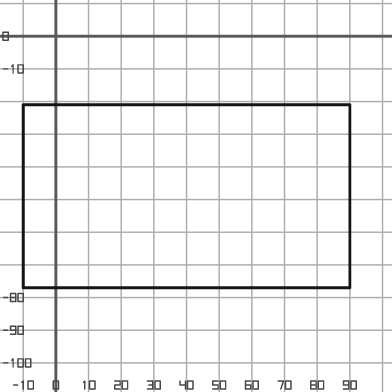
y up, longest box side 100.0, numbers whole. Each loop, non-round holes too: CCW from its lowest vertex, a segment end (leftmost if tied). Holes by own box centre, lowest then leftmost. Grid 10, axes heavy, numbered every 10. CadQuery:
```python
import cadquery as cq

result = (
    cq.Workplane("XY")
    .moveTo(-10.0, -77.0)
    .lineTo(90.0, -77.0)
    .lineTo(90.0, -21.0)
    .lineTo(-10.0, -21.0)
    .close()
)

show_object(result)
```